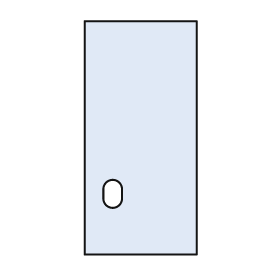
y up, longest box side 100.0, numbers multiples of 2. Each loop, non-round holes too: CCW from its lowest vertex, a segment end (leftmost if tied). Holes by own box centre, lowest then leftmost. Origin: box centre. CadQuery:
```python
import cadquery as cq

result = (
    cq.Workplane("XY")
    .moveTo(-24.0, -50.0)
    .lineTo(24.0, -50.0)
    .lineTo(24.0, 50.0)
    .lineTo(-24.0, 50.0)
    .close()
    .moveTo(-16.0, -26.0)
    .threePointArc((-12.0, -30.0), (-8.0, -26.0))
    .lineTo(-8.0, -22.0)
    .threePointArc((-12.0, -18.0), (-16.0, -22.0))
    .close()
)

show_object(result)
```